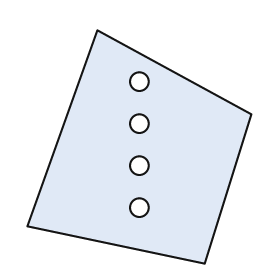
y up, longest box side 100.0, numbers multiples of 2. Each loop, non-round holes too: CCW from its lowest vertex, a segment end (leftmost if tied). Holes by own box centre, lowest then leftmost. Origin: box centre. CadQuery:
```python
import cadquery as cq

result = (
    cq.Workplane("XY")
    .moveTo(28.0, -50.0)
    .lineTo(48.0, 14.0)
    .lineTo(-18.0, 50.0)
    .lineTo(-48.0, -34.0)
    .close()
    .moveTo(0.0, -26.0)
    .circle(4.0)
    .moveTo(0.0, -8.0)
    .circle(4.0)
    .moveTo(0.0, 10.0)
    .circle(4.0)
    .moveTo(0.0, 28.0)
    .circle(4.0)
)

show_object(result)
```